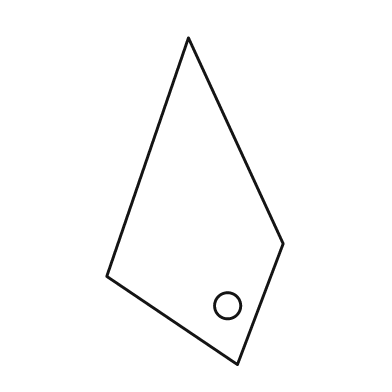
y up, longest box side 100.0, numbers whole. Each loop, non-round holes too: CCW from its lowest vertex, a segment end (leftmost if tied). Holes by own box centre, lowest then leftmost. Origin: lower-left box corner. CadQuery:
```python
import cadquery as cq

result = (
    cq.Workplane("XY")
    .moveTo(40.0, 0.0)
    .lineTo(54.0, 37.0)
    .lineTo(25.0, 100.0)
    .lineTo(0.0, 27.0)
    .close()
    .moveTo(37.0, 18.0)
    .circle(4.0)
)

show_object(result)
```